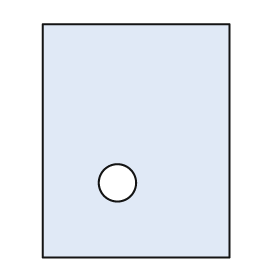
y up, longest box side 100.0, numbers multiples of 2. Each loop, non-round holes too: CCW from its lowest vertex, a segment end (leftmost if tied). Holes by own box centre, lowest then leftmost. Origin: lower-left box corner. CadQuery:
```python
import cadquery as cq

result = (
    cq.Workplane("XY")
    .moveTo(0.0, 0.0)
    .lineTo(80.0, 0.0)
    .lineTo(80.0, 100.0)
    .lineTo(0.0, 100.0)
    .close()
    .moveTo(32.0, 32.0)
    .circle(8.0)
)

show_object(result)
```